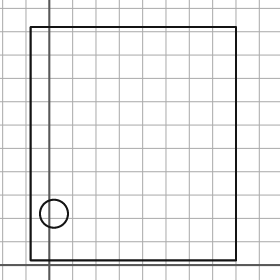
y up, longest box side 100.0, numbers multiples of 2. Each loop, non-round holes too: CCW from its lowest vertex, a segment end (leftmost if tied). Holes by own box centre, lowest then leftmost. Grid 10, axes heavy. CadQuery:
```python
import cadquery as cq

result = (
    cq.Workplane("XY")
    .moveTo(-8.0, 2.0)
    .lineTo(80.0, 2.0)
    .lineTo(80.0, 102.0)
    .lineTo(-8.0, 102.0)
    .close()
    .moveTo(2.0, 22.0)
    .circle(6.0)
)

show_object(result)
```